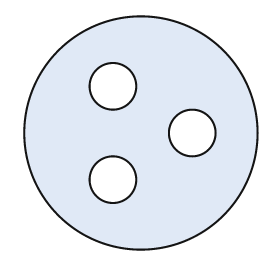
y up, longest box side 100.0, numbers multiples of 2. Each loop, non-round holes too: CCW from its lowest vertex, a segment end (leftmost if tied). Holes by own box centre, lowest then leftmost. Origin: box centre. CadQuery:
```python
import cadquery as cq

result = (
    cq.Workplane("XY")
    .moveTo(0.0, 0.0)
    .circle(50.0)
    .moveTo(-12.0, -20.0)
    .circle(10.0)
    .moveTo(22.0, 0.0)
    .circle(10.0)
    .moveTo(-12.0, 20.0)
    .circle(10.0)
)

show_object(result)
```